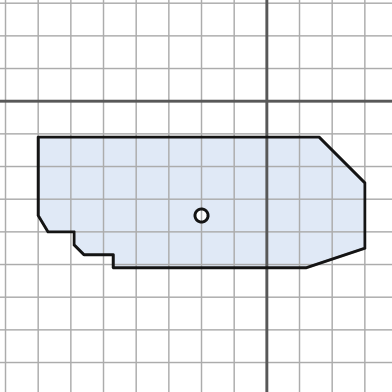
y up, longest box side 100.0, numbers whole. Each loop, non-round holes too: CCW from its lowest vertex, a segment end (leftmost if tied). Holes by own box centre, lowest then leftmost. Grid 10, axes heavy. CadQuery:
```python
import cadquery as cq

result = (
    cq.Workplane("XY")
    .moveTo(-47.0, -51.0)
    .lineTo(12.0, -51.0)
    .lineTo(30.0, -45.0)
    .lineTo(30.0, -25.0)
    .lineTo(16.0, -11.0)
    .lineTo(-70.0, -11.0)
    .lineTo(-70.0, -35.0)
    .lineTo(-67.0, -40.0)
    .lineTo(-59.0, -40.0)
    .lineTo(-59.0, -44.0)
    .lineTo(-56.0, -47.0)
    .lineTo(-47.0, -47.0)
    .close()
    .moveTo(-20.0, -35.0)
    .circle(2.0)
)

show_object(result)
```